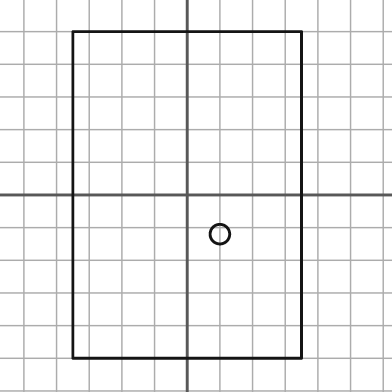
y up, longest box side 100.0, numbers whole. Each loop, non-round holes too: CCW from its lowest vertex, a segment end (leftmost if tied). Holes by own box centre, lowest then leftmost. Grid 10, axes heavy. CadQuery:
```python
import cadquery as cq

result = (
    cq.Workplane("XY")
    .moveTo(-35.0, -50.0)
    .lineTo(35.0, -50.0)
    .lineTo(35.0, 50.0)
    .lineTo(-35.0, 50.0)
    .close()
    .moveTo(10.0, -12.0)
    .circle(3.0)
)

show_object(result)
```